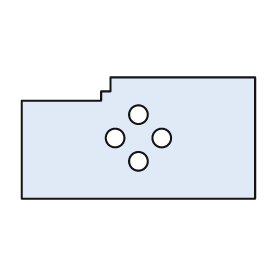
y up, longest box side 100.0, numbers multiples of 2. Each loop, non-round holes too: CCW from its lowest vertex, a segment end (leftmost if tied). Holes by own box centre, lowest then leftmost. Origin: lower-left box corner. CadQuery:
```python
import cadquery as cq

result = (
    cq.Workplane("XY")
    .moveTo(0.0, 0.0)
    .lineTo(100.0, 0.0)
    .lineTo(100.0, 52.0)
    .lineTo(38.0, 52.0)
    .lineTo(38.0, 46.0)
    .lineTo(34.0, 46.0)
    .lineTo(34.0, 42.0)
    .lineTo(0.0, 42.0)
    .close()
    .moveTo(50.0, 16.0)
    .circle(4.0)
    .moveTo(40.0, 26.0)
    .circle(4.0)
    .moveTo(60.0, 26.0)
    .circle(4.0)
    .moveTo(50.0, 36.0)
    .circle(4.0)
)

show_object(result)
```